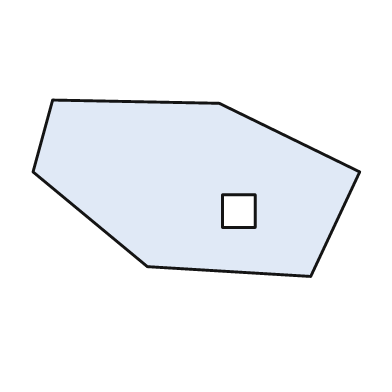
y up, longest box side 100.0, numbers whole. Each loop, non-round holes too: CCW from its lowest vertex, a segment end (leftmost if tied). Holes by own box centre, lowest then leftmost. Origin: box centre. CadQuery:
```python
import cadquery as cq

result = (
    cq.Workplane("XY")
    .moveTo(35.0, -27.0)
    .lineTo(50.0, 5.0)
    .lineTo(7.0, 26.0)
    .lineTo(-44.0, 27.0)
    .lineTo(-50.0, 5.0)
    .lineTo(-15.0, -24.0)
    .close()
    .moveTo(8.0, -12.0)
    .lineTo(18.0, -12.0)
    .lineTo(18.0, -2.0)
    .lineTo(8.0, -2.0)
    .close()
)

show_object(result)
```